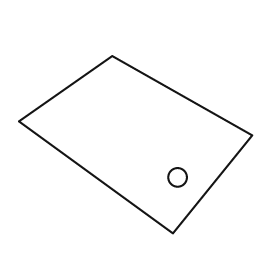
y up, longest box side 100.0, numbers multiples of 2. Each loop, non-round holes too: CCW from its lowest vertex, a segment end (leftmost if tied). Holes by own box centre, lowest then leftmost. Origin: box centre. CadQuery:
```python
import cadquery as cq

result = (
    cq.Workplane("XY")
    .moveTo(16.0, -38.0)
    .lineTo(50.0, 4.0)
    .lineTo(-10.0, 38.0)
    .lineTo(-50.0, 10.0)
    .close()
    .moveTo(18.0, -14.0)
    .circle(4.0)
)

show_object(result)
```